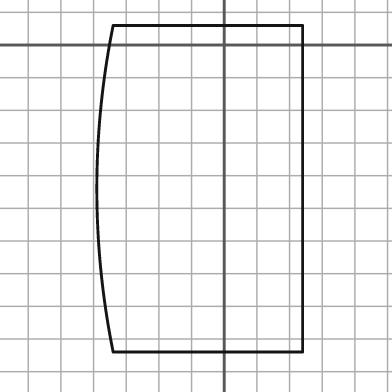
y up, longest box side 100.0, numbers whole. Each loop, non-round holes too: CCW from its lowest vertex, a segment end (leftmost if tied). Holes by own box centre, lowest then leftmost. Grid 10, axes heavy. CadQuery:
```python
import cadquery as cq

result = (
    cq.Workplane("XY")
    .moveTo(-34.0, -94.0)
    .lineTo(24.0, -94.0)
    .lineTo(24.0, 6.0)
    .lineTo(-34.0, 6.0)
    .threePointArc((-39.0, -44.0), (-34.0, -94.0))
    .close()
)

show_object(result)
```